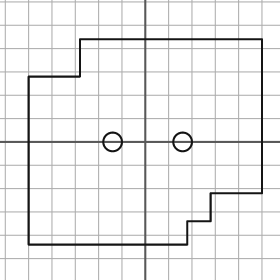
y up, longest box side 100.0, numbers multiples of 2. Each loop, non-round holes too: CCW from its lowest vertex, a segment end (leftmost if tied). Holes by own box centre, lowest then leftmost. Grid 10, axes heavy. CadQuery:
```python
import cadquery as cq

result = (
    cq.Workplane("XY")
    .moveTo(-50.0, -44.0)
    .lineTo(18.0, -44.0)
    .lineTo(18.0, -34.0)
    .lineTo(28.0, -34.0)
    .lineTo(28.0, -22.0)
    .lineTo(50.0, -22.0)
    .lineTo(50.0, 44.0)
    .lineTo(-28.0, 44.0)
    .lineTo(-28.0, 28.0)
    .lineTo(-50.0, 28.0)
    .close()
    .moveTo(-14.0, 0.0)
    .circle(4.0)
    .moveTo(16.0, 0.0)
    .circle(4.0)
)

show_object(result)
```